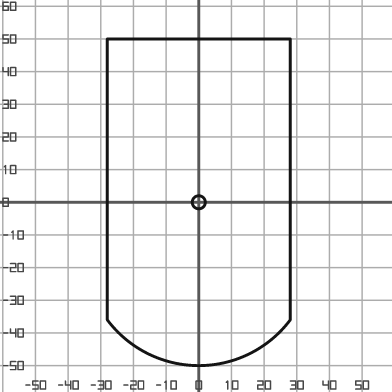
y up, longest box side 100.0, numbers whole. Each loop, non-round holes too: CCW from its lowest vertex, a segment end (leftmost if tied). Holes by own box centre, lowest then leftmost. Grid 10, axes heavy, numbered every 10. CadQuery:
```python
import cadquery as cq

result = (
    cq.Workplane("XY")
    .moveTo(-28.0, -36.0)
    .threePointArc((0.0, -50.0), (28.0, -36.0))
    .lineTo(28.0, 50.0)
    .lineTo(-28.0, 50.0)
    .close()
    .moveTo(0.0, 0.0)
    .circle(2.0)
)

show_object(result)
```